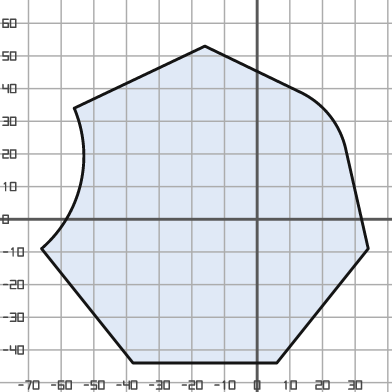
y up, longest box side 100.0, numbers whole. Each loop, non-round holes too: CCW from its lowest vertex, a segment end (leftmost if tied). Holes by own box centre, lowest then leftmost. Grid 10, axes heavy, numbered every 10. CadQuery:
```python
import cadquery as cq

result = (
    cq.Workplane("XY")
    .moveTo(-38.0, -44.0)
    .lineTo(6.0, -44.0)
    .lineTo(34.0, -9.0)
    .lineTo(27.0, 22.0)
    .threePointArc((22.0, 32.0), (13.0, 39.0))
    .lineTo(-16.0, 53.0)
    .lineTo(-56.0, 34.0)
    .threePointArc((-54.0, 11.0), (-66.0, -9.0))
    .close()
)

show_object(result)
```